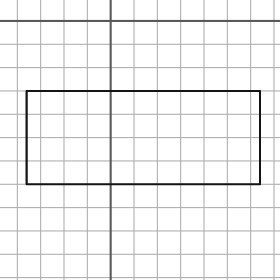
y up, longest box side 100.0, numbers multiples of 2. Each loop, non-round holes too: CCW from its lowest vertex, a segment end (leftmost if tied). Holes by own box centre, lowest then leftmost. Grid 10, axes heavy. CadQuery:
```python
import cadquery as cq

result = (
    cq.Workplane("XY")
    .moveTo(-36.0, -70.0)
    .lineTo(64.0, -70.0)
    .lineTo(64.0, -30.0)
    .lineTo(-36.0, -30.0)
    .close()
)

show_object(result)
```